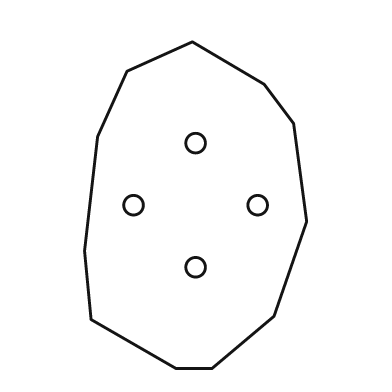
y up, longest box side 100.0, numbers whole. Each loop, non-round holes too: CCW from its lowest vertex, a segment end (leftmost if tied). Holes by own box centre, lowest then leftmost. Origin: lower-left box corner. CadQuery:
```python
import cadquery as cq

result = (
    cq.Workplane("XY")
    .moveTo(28.0, 0.0)
    .lineTo(39.0, 0.0)
    .lineTo(58.0, 16.0)
    .lineTo(68.0, 45.0)
    .lineTo(64.0, 75.0)
    .lineTo(55.0, 87.0)
    .lineTo(33.0, 100.0)
    .lineTo(13.0, 91.0)
    .lineTo(4.0, 71.0)
    .lineTo(0.0, 36.0)
    .lineTo(2.0, 15.0)
    .close()
    .moveTo(34.0, 31.0)
    .circle(3.0)
    .moveTo(15.0, 50.0)
    .circle(3.0)
    .moveTo(53.0, 50.0)
    .circle(3.0)
    .moveTo(34.0, 69.0)
    .circle(3.0)
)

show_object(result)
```